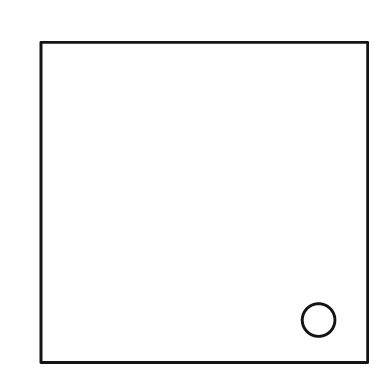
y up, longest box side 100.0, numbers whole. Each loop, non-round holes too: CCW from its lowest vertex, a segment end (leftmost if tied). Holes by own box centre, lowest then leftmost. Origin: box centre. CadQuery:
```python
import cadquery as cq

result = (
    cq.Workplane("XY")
    .moveTo(-50.0, -49.0)
    .lineTo(50.0, -49.0)
    .lineTo(50.0, 49.0)
    .lineTo(-50.0, 49.0)
    .close()
    .moveTo(35.0, -36.0)
    .circle(5.0)
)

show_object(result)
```